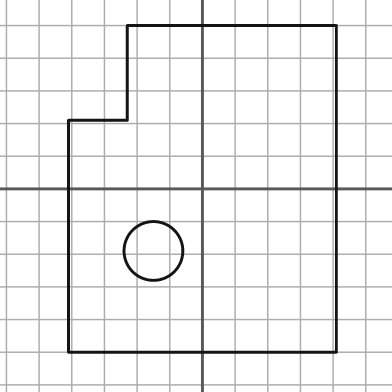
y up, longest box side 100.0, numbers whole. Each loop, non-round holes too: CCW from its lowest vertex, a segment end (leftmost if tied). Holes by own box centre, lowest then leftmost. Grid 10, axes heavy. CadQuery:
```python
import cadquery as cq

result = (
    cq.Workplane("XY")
    .moveTo(-41.0, -50.0)
    .lineTo(41.0, -50.0)
    .lineTo(41.0, 50.0)
    .lineTo(-23.0, 50.0)
    .lineTo(-23.0, 21.0)
    .lineTo(-41.0, 21.0)
    .close()
    .moveTo(-15.0, -19.0)
    .circle(9.0)
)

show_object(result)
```